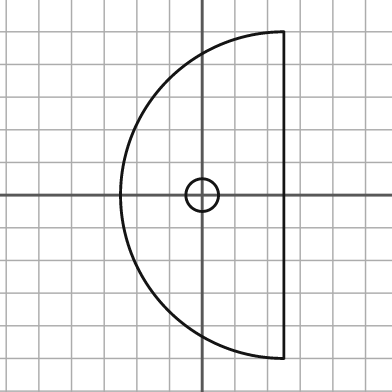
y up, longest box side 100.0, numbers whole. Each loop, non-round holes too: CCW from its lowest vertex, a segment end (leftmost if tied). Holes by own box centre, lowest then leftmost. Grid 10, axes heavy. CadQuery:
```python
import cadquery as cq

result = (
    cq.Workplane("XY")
    .moveTo(25.0, -50.0)
    .lineTo(25.0, 50.0)
    .threePointArc((-25.0, 0.0), (25.0, -50.0))
    .close()
    .moveTo(0.0, 0.0)
    .circle(5.0)
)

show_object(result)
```